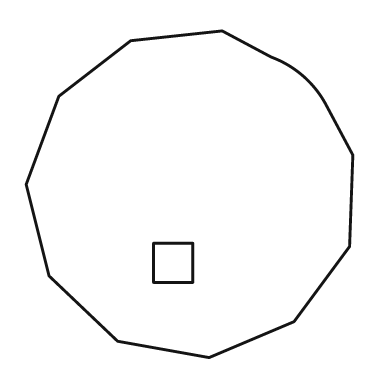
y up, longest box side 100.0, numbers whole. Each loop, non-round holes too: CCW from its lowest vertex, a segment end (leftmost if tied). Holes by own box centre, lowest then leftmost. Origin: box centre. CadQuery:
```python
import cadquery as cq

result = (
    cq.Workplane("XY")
    .moveTo(6.0, -50.0)
    .lineTo(32.0, -39.0)
    .lineTo(49.0, -16.0)
    .lineTo(50.0, 12.0)
    .lineTo(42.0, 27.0)
    .threePointArc((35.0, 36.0), (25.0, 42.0))
    .lineTo(10.0, 50.0)
    .lineTo(-18.0, 47.0)
    .lineTo(-40.0, 30.0)
    .lineTo(-50.0, 3.0)
    .lineTo(-43.0, -25.0)
    .lineTo(-22.0, -45.0)
    .close()
    .moveTo(-11.0, -27.0)
    .lineTo(1.0, -27.0)
    .lineTo(1.0, -15.0)
    .lineTo(-11.0, -15.0)
    .close()
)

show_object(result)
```